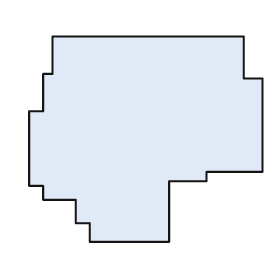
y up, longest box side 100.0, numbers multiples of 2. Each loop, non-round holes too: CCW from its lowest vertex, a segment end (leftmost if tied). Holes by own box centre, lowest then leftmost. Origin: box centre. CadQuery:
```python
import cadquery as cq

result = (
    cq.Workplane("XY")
    .moveTo(-24.0, -44.0)
    .lineTo(10.0, -44.0)
    .lineTo(10.0, -18.0)
    .lineTo(26.0, -18.0)
    .lineTo(26.0, -14.0)
    .lineTo(50.0, -14.0)
    .lineTo(50.0, 26.0)
    .lineTo(42.0, 26.0)
    .lineTo(42.0, 44.0)
    .lineTo(-40.0, 44.0)
    .lineTo(-40.0, 28.0)
    .lineTo(-44.0, 28.0)
    .lineTo(-44.0, 12.0)
    .lineTo(-50.0, 12.0)
    .lineTo(-50.0, -20.0)
    .lineTo(-44.0, -20.0)
    .lineTo(-44.0, -26.0)
    .lineTo(-30.0, -26.0)
    .lineTo(-30.0, -36.0)
    .lineTo(-24.0, -36.0)
    .close()
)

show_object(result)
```